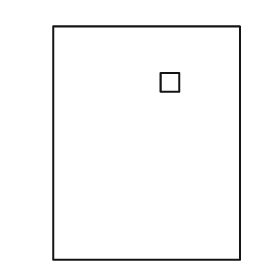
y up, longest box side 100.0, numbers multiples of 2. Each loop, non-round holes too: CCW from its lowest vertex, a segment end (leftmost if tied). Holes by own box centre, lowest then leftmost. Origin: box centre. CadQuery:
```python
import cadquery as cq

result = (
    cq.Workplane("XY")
    .moveTo(-40.0, -50.0)
    .lineTo(40.0, -50.0)
    .lineTo(40.0, 50.0)
    .lineTo(-40.0, 50.0)
    .close()
    .moveTo(6.0, 22.0)
    .lineTo(14.0, 22.0)
    .lineTo(14.0, 30.0)
    .lineTo(6.0, 30.0)
    .close()
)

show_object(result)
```